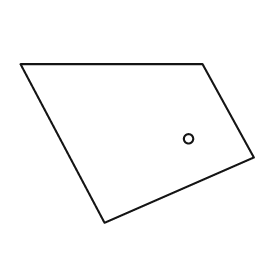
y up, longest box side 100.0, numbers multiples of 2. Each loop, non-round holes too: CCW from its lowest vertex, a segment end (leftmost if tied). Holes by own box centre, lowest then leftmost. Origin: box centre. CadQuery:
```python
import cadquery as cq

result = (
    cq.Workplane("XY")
    .moveTo(-14.0, -34.0)
    .lineTo(50.0, -6.0)
    .lineTo(28.0, 34.0)
    .lineTo(-50.0, 34.0)
    .close()
    .moveTo(22.0, 2.0)
    .circle(2.0)
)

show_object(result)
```